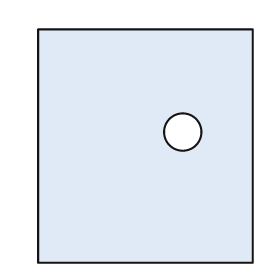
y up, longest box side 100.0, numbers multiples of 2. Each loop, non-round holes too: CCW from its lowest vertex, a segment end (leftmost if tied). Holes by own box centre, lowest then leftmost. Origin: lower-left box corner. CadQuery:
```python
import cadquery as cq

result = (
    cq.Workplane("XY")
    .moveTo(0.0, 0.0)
    .lineTo(92.0, 0.0)
    .lineTo(92.0, 100.0)
    .lineTo(0.0, 100.0)
    .close()
    .moveTo(62.0, 56.0)
    .circle(8.0)
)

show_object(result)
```